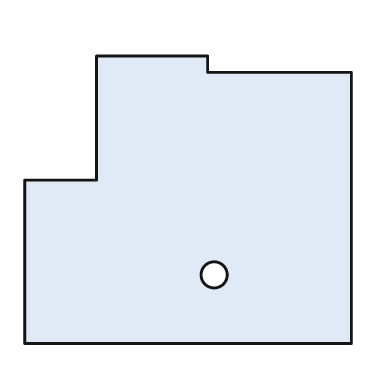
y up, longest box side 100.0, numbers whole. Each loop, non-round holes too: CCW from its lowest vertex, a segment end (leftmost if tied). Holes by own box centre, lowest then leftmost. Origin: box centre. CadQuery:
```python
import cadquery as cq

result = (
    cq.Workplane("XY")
    .moveTo(-50.0, -44.0)
    .lineTo(50.0, -44.0)
    .lineTo(50.0, 39.0)
    .lineTo(6.0, 39.0)
    .lineTo(6.0, 44.0)
    .lineTo(-28.0, 44.0)
    .lineTo(-28.0, 6.0)
    .lineTo(-50.0, 6.0)
    .close()
    .moveTo(8.0, -23.0)
    .circle(4.0)
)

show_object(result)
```